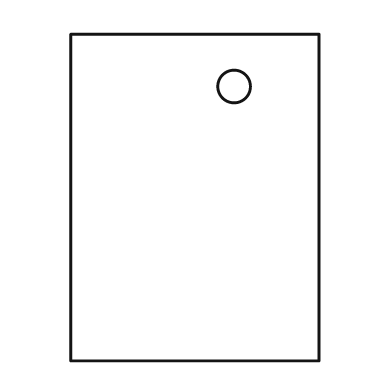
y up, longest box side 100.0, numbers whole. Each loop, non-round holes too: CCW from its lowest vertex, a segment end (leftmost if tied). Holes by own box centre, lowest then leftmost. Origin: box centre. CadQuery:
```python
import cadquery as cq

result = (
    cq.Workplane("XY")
    .moveTo(-38.0, -50.0)
    .lineTo(38.0, -50.0)
    .lineTo(38.0, 50.0)
    .lineTo(-38.0, 50.0)
    .close()
    .moveTo(12.0, 34.0)
    .circle(5.0)
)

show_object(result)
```